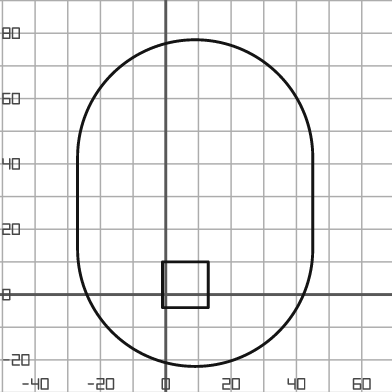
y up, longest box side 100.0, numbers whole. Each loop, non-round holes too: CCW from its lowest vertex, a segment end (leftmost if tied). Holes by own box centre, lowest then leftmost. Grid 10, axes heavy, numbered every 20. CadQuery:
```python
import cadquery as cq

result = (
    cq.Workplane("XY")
    .moveTo(-27.0, 14.0)
    .threePointArc((9.0, -22.0), (45.0, 14.0))
    .lineTo(45.0, 42.0)
    .threePointArc((9.0, 78.0), (-27.0, 42.0))
    .close()
    .moveTo(-1.0, -4.0)
    .lineTo(13.0, -4.0)
    .lineTo(13.0, 10.0)
    .lineTo(-1.0, 10.0)
    .close()
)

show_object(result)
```